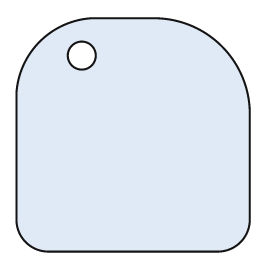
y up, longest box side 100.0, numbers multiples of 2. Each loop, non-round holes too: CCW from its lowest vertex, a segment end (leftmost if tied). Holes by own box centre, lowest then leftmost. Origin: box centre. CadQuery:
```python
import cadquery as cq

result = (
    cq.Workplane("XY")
    .moveTo(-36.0, -50.0)
    .lineTo(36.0, -50.0)
    .threePointArc((46.0, -46.0), (50.0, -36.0))
    .lineTo(50.0, 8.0)
    .threePointArc((38.0, 38.0), (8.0, 50.0))
    .lineTo(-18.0, 50.0)
    .threePointArc((-40.0, 40.0), (-50.0, 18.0))
    .lineTo(-50.0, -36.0)
    .threePointArc((-46.0, -46.0), (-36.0, -50.0))
    .close()
    .moveTo(-22.0, 34.0)
    .circle(6.0)
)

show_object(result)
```